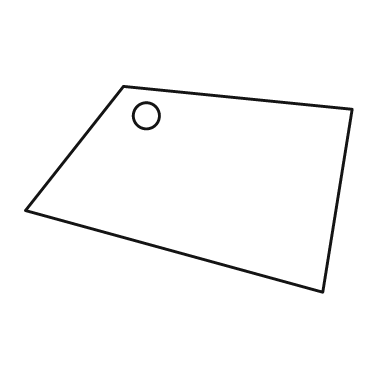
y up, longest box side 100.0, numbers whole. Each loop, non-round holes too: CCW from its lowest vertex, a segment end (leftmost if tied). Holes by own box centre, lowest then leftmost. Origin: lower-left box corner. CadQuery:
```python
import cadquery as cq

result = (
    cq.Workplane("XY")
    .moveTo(91.0, 0.0)
    .lineTo(100.0, 56.0)
    .lineTo(30.0, 63.0)
    .lineTo(0.0, 25.0)
    .close()
    .moveTo(37.0, 54.0)
    .circle(4.0)
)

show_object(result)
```